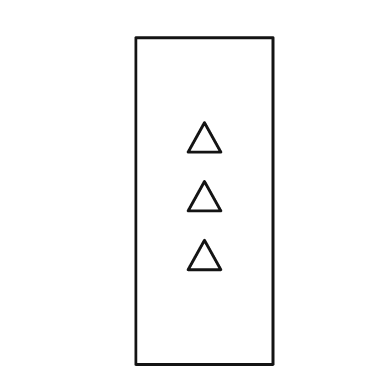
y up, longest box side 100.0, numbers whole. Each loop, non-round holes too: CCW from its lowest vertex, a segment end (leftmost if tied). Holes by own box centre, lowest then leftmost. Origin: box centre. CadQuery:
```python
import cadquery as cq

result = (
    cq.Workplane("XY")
    .moveTo(-21.0, -50.0)
    .lineTo(21.0, -50.0)
    .lineTo(21.0, 50.0)
    .lineTo(-21.0, 50.0)
    .close()
    .moveTo(-5.0, -21.0)
    .lineTo(5.0, -21.0)
    .lineTo(0.0, -12.0)
    .close()
    .moveTo(-5.0, -3.0)
    .lineTo(5.0, -3.0)
    .lineTo(0.0, 6.0)
    .close()
    .moveTo(-5.0, 15.0)
    .lineTo(5.0, 15.0)
    .lineTo(0.0, 24.0)
    .close()
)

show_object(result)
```